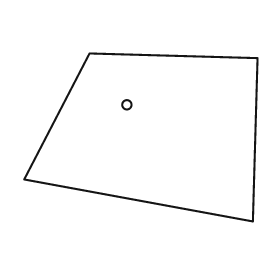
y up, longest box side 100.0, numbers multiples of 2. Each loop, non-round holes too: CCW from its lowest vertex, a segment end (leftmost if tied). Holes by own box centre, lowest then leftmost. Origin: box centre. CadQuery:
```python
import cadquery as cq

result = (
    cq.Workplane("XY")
    .moveTo(48.0, -36.0)
    .lineTo(50.0, 34.0)
    .lineTo(-22.0, 36.0)
    .lineTo(-50.0, -18.0)
    .close()
    .moveTo(-6.0, 14.0)
    .circle(2.0)
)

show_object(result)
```